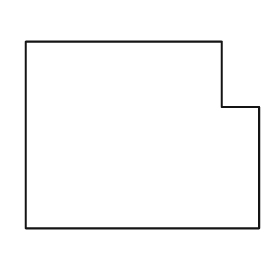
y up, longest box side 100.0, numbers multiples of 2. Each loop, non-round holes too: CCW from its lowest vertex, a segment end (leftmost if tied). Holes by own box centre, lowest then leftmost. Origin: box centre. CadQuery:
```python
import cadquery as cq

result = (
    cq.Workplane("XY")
    .moveTo(-50.0, -40.0)
    .lineTo(50.0, -40.0)
    .lineTo(50.0, 12.0)
    .lineTo(34.0, 12.0)
    .lineTo(34.0, 40.0)
    .lineTo(-50.0, 40.0)
    .close()
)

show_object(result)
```